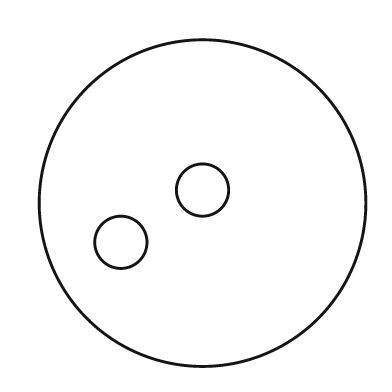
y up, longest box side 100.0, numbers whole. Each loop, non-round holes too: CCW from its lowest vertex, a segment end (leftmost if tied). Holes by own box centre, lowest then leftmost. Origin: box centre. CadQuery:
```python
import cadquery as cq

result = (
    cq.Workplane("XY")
    .moveTo(0.0, 0.0)
    .circle(50.0)
    .moveTo(-25.0, -12.0)
    .circle(8.0)
    .moveTo(0.0, 4.0)
    .circle(8.0)
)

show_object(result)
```